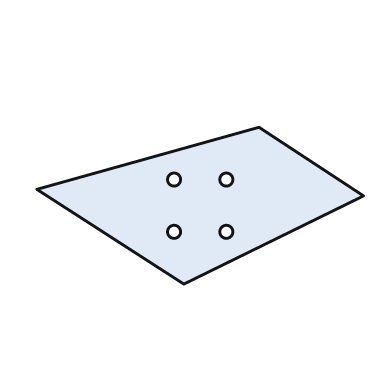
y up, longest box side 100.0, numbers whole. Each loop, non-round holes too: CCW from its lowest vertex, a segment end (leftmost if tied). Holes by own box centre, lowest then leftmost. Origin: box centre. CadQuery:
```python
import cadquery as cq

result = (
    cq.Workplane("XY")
    .moveTo(-5.0, -24.0)
    .lineTo(50.0, 3.0)
    .lineTo(18.0, 24.0)
    .lineTo(-50.0, 5.0)
    .close()
    .moveTo(-8.0, -8.0)
    .circle(2.0)
    .moveTo(8.0, -8.0)
    .circle(2.0)
    .moveTo(-8.0, 8.0)
    .circle(2.0)
    .moveTo(8.0, 8.0)
    .circle(2.0)
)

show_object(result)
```